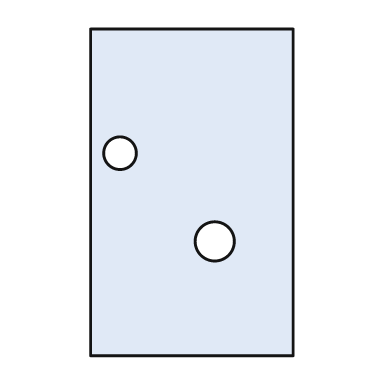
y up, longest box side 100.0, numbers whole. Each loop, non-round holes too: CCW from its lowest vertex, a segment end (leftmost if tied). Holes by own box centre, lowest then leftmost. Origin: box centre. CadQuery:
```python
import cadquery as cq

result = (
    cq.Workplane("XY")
    .moveTo(-31.0, -50.0)
    .lineTo(31.0, -50.0)
    .lineTo(31.0, 50.0)
    .lineTo(-31.0, 50.0)
    .close()
    .moveTo(7.0, -15.0)
    .circle(6.0)
    .moveTo(-22.0, 12.0)
    .circle(5.0)
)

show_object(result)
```